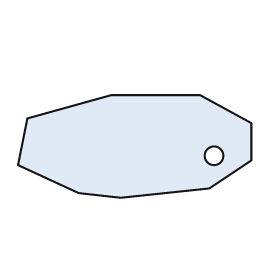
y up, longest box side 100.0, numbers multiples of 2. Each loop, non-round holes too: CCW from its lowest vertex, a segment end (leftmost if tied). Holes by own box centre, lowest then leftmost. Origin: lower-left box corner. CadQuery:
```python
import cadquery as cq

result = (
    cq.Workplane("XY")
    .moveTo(44.0, 0.0)
    .lineTo(82.0, 4.0)
    .lineTo(100.0, 16.0)
    .lineTo(100.0, 32.0)
    .lineTo(78.0, 44.0)
    .lineTo(40.0, 44.0)
    .lineTo(4.0, 34.0)
    .lineTo(0.0, 14.0)
    .lineTo(26.0, 2.0)
    .close()
    .moveTo(84.0, 18.0)
    .circle(4.0)
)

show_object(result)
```